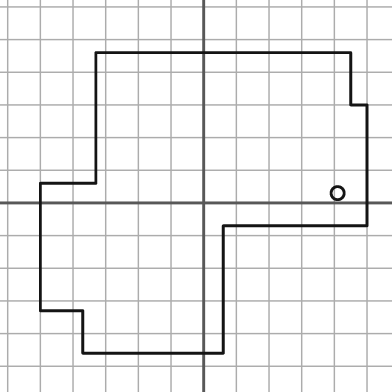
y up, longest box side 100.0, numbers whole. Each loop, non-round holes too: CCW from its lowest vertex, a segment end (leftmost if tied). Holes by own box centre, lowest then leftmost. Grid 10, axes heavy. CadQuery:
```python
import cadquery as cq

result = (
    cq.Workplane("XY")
    .moveTo(-37.0, -46.0)
    .lineTo(6.0, -46.0)
    .lineTo(6.0, -7.0)
    .lineTo(50.0, -7.0)
    .lineTo(50.0, 30.0)
    .lineTo(45.0, 30.0)
    .lineTo(45.0, 46.0)
    .lineTo(-33.0, 46.0)
    .lineTo(-33.0, 6.0)
    .lineTo(-50.0, 6.0)
    .lineTo(-50.0, -33.0)
    .lineTo(-37.0, -33.0)
    .close()
    .moveTo(41.0, 3.0)
    .circle(2.0)
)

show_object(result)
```